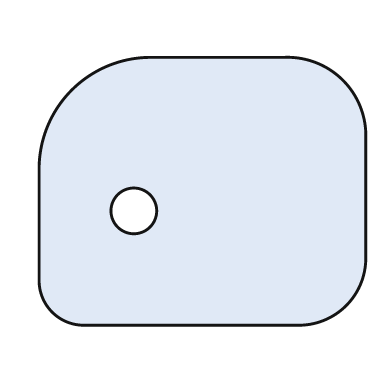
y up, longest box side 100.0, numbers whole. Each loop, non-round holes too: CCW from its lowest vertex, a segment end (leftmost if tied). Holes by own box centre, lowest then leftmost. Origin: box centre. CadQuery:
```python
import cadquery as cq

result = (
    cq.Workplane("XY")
    .moveTo(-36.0, -41.0)
    .lineTo(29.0, -41.0)
    .threePointArc((44.0, -35.0), (50.0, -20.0))
    .lineTo(50.0, 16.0)
    .threePointArc((43.0, 34.0), (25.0, 41.0))
    .lineTo(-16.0, 41.0)
    .threePointArc((-40.0, 31.0), (-50.0, 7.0))
    .lineTo(-50.0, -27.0)
    .threePointArc((-46.0, -37.0), (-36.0, -41.0))
    .close()
    .moveTo(-21.0, -6.0)
    .circle(7.0)
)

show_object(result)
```